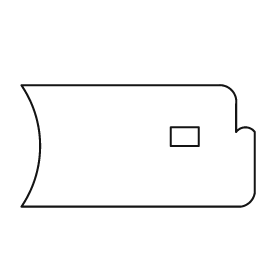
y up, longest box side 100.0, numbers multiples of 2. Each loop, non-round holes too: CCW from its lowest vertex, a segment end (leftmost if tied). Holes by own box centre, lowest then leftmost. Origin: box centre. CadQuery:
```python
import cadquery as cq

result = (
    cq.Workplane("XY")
    .moveTo(-50.0, -26.0)
    .lineTo(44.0, -26.0)
    .threePointArc((48.0, -24.0), (50.0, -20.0))
    .lineTo(50.0, 6.0)
    .threePointArc((46.0, 8.0), (42.0, 6.0))
    .lineTo(42.0, 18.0)
    .threePointArc((40.0, 24.0), (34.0, 26.0))
    .lineTo(-50.0, 26.0)
    .threePointArc((-42.0, 0.0), (-50.0, -26.0))
    .close()
    .moveTo(14.0, 0.0)
    .lineTo(26.0, 0.0)
    .lineTo(26.0, 8.0)
    .lineTo(14.0, 8.0)
    .close()
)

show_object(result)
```